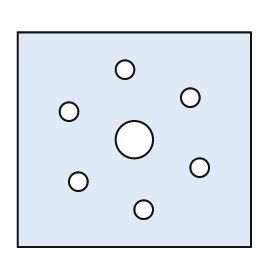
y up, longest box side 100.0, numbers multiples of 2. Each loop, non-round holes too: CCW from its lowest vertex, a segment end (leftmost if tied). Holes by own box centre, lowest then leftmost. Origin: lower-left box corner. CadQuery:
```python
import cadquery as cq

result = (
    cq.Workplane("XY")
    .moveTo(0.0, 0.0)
    .lineTo(100.0, 0.0)
    .lineTo(100.0, 92.0)
    .lineTo(0.0, 92.0)
    .close()
    .moveTo(54.0, 16.0)
    .circle(4.0)
    .moveTo(26.0, 28.0)
    .circle(4.0)
    .moveTo(78.0, 34.0)
    .circle(4.0)
    .moveTo(50.0, 46.0)
    .circle(8.0)
    .moveTo(22.0, 58.0)
    .circle(4.0)
    .moveTo(74.0, 64.0)
    .circle(4.0)
    .moveTo(46.0, 76.0)
    .circle(4.0)
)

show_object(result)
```